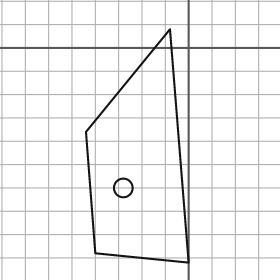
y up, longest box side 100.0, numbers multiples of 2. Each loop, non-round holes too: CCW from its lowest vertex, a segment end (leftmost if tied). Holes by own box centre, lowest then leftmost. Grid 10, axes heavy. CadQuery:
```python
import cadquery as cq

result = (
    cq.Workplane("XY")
    .moveTo(0.0, -92.0)
    .lineTo(-8.0, 8.0)
    .lineTo(-44.0, -36.0)
    .lineTo(-40.0, -88.0)
    .close()
    .moveTo(-28.0, -60.0)
    .circle(4.0)
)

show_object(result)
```